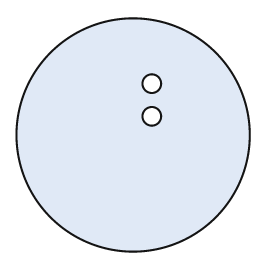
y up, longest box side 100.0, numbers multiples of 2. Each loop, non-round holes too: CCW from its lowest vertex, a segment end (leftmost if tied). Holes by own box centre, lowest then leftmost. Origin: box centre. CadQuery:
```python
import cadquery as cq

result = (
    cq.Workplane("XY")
    .moveTo(0.0, 0.0)
    .circle(50.0)
    .moveTo(8.0, 8.0)
    .circle(4.0)
    .moveTo(8.0, 22.0)
    .circle(4.0)
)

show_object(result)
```